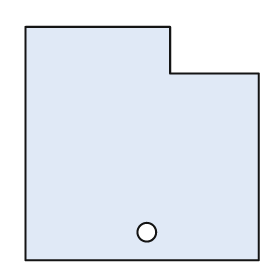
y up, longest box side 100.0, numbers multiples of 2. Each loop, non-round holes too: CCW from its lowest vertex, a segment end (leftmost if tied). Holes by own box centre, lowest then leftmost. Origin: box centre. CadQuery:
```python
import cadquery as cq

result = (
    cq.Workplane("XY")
    .moveTo(-50.0, -50.0)
    .lineTo(50.0, -50.0)
    .lineTo(50.0, 30.0)
    .lineTo(12.0, 30.0)
    .lineTo(12.0, 50.0)
    .lineTo(-50.0, 50.0)
    .close()
    .moveTo(2.0, -38.0)
    .circle(4.0)
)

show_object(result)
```